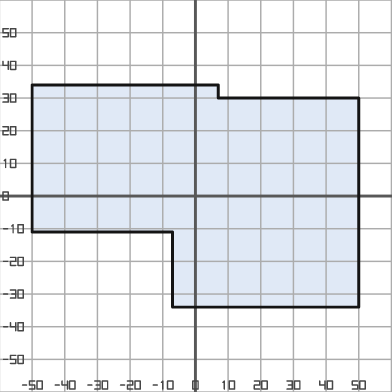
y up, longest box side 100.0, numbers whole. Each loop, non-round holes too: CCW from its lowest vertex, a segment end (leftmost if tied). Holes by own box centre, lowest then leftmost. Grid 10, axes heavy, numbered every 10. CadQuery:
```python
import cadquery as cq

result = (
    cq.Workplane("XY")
    .moveTo(-7.0, -34.0)
    .lineTo(50.0, -34.0)
    .lineTo(50.0, 30.0)
    .lineTo(7.0, 30.0)
    .lineTo(7.0, 34.0)
    .lineTo(-50.0, 34.0)
    .lineTo(-50.0, -11.0)
    .lineTo(-7.0, -11.0)
    .close()
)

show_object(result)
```